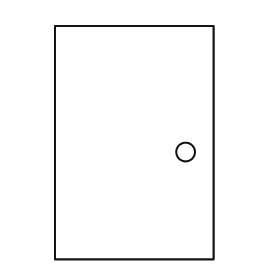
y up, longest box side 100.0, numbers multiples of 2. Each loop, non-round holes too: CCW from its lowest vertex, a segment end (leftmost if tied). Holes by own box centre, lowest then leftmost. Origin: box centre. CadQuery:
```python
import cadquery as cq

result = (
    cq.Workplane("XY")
    .moveTo(-34.0, -50.0)
    .lineTo(34.0, -50.0)
    .lineTo(34.0, 50.0)
    .lineTo(-34.0, 50.0)
    .close()
    .moveTo(22.0, -4.0)
    .circle(4.0)
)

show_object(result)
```